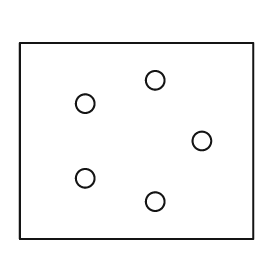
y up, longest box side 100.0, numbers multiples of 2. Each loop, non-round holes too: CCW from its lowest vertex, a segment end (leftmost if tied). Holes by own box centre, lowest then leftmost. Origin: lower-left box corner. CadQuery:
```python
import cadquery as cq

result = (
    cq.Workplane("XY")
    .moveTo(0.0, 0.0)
    .lineTo(100.0, 0.0)
    .lineTo(100.0, 84.0)
    .lineTo(0.0, 84.0)
    .close()
    .moveTo(58.0, 16.0)
    .circle(4.0)
    .moveTo(28.0, 26.0)
    .circle(4.0)
    .moveTo(78.0, 42.0)
    .circle(4.0)
    .moveTo(28.0, 58.0)
    .circle(4.0)
    .moveTo(58.0, 68.0)
    .circle(4.0)
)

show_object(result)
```